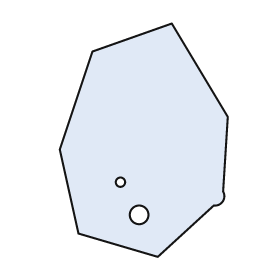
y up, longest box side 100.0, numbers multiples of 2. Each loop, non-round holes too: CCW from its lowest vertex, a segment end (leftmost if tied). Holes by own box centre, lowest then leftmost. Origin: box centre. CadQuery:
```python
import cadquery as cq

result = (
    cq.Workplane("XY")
    .moveTo(6.0, -50.0)
    .lineTo(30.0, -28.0)
    .threePointArc((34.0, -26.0), (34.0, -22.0))
    .lineTo(36.0, 10.0)
    .lineTo(12.0, 50.0)
    .lineTo(-22.0, 38.0)
    .lineTo(-36.0, -4.0)
    .lineTo(-28.0, -40.0)
    .close()
    .moveTo(-2.0, -32.0)
    .circle(4.0)
    .moveTo(-10.0, -18.0)
    .circle(2.0)
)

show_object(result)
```